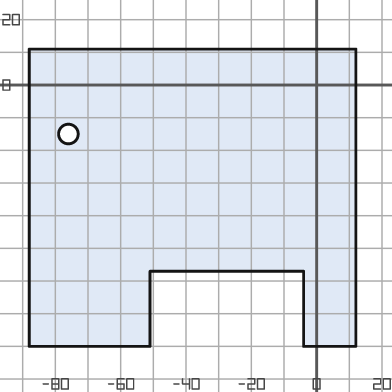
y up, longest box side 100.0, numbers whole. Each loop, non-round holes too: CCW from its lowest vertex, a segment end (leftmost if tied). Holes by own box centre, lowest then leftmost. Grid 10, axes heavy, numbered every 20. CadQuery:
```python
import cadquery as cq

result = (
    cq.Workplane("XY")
    .moveTo(-88.0, -80.0)
    .lineTo(-51.0, -80.0)
    .lineTo(-51.0, -57.0)
    .lineTo(-4.0, -57.0)
    .lineTo(-4.0, -80.0)
    .lineTo(12.0, -80.0)
    .lineTo(12.0, 11.0)
    .lineTo(-88.0, 11.0)
    .close()
    .moveTo(-76.0, -15.0)
    .circle(3.0)
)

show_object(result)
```